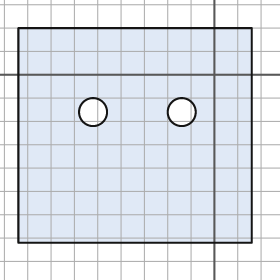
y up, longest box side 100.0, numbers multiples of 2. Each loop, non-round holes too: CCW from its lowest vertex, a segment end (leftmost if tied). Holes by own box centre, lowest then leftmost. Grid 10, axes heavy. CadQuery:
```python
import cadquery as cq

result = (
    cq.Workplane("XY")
    .moveTo(-84.0, -72.0)
    .lineTo(16.0, -72.0)
    .lineTo(16.0, 20.0)
    .lineTo(-84.0, 20.0)
    .close()
    .moveTo(-52.0, -16.0)
    .circle(6.0)
    .moveTo(-14.0, -16.0)
    .circle(6.0)
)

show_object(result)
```